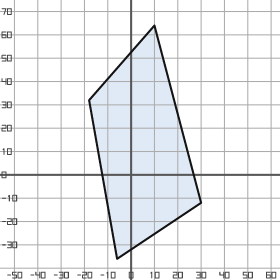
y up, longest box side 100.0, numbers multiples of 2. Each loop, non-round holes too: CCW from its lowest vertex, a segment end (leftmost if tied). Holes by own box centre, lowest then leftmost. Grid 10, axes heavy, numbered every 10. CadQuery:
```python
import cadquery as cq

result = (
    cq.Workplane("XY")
    .moveTo(-6.0, -36.0)
    .lineTo(30.0, -12.0)
    .lineTo(10.0, 64.0)
    .lineTo(-18.0, 32.0)
    .close()
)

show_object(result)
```